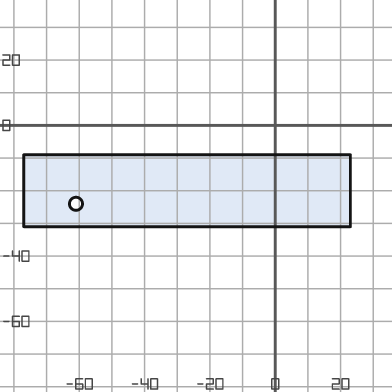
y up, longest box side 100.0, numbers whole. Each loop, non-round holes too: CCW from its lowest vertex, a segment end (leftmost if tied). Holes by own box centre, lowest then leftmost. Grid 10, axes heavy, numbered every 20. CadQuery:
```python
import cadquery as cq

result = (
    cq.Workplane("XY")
    .moveTo(-77.0, -31.0)
    .lineTo(23.0, -31.0)
    .lineTo(23.0, -9.0)
    .lineTo(-77.0, -9.0)
    .close()
    .moveTo(-61.0, -24.0)
    .circle(2.0)
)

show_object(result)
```